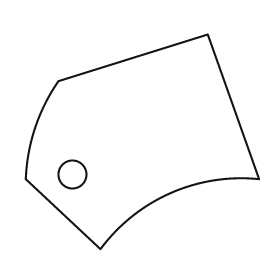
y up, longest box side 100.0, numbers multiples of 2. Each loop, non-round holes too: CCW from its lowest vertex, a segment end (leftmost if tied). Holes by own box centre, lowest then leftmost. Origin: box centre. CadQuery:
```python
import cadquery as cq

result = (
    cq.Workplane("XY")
    .moveTo(-18.0, -46.0)
    .threePointArc((12.0, -22.0), (50.0, -16.0))
    .lineTo(28.0, 46.0)
    .lineTo(-36.0, 26.0)
    .threePointArc((-46.0, 6.0), (-50.0, -16.0))
    .close()
    .moveTo(-30.0, -14.0)
    .circle(6.0)
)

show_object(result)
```